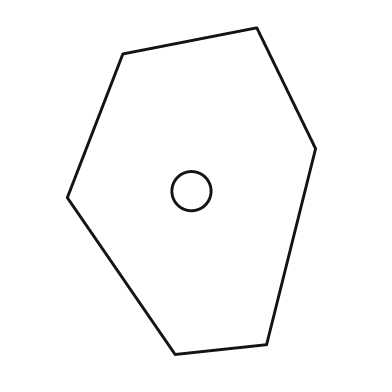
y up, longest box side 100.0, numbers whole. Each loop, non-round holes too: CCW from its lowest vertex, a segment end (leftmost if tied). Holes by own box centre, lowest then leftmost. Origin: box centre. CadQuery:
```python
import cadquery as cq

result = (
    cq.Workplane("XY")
    .moveTo(-5.0, -50.0)
    .lineTo(23.0, -47.0)
    .lineTo(38.0, 13.0)
    .lineTo(20.0, 50.0)
    .lineTo(-21.0, 42.0)
    .lineTo(-38.0, -2.0)
    .close()
    .moveTo(0.0, 0.0)
    .circle(6.0)
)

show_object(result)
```